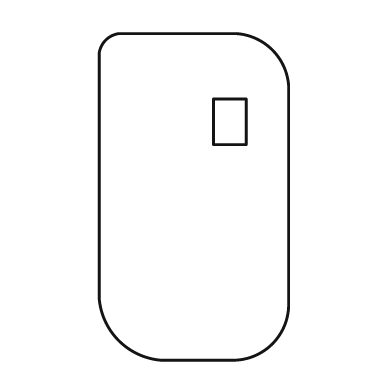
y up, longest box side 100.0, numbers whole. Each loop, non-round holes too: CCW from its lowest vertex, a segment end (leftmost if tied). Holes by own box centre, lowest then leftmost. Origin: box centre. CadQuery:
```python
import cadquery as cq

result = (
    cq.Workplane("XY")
    .moveTo(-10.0, -50.0)
    .lineTo(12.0, -50.0)
    .threePointArc((24.0, -45.0), (29.0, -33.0))
    .lineTo(29.0, 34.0)
    .threePointArc((24.0, 45.0), (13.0, 50.0))
    .lineTo(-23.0, 50.0)
    .threePointArc((-27.0, 48.0), (-29.0, 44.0))
    .lineTo(-29.0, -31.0)
    .threePointArc((-23.0, -44.0), (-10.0, -50.0))
    .close()
    .moveTo(6.0, 16.0)
    .lineTo(16.0, 16.0)
    .lineTo(16.0, 30.0)
    .lineTo(6.0, 30.0)
    .close()
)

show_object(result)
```